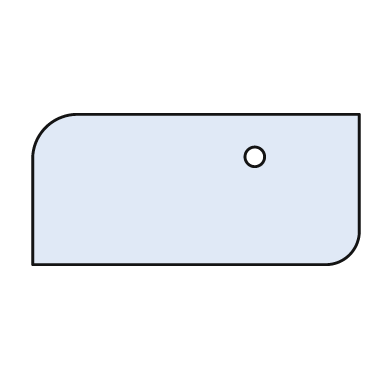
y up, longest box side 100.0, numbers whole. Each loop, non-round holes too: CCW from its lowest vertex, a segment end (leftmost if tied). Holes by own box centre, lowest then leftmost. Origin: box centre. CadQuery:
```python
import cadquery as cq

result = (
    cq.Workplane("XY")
    .moveTo(-50.0, -23.0)
    .lineTo(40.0, -23.0)
    .threePointArc((47.0, -20.0), (50.0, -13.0))
    .lineTo(50.0, 23.0)
    .lineTo(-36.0, 23.0)
    .threePointArc((-46.0, 19.0), (-50.0, 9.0))
    .close()
    .moveTo(18.0, 10.0)
    .circle(3.0)
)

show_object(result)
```